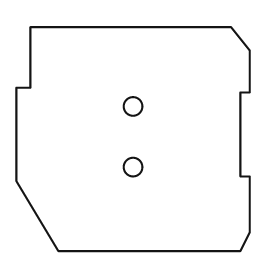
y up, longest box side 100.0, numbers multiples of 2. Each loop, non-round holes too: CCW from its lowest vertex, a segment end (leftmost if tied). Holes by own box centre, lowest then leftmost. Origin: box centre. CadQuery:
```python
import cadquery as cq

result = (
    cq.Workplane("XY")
    .moveTo(-32.0, -48.0)
    .lineTo(46.0, -48.0)
    .lineTo(50.0, -40.0)
    .lineTo(50.0, -16.0)
    .lineTo(46.0, -16.0)
    .lineTo(46.0, 20.0)
    .lineTo(50.0, 20.0)
    .lineTo(50.0, 38.0)
    .lineTo(42.0, 48.0)
    .lineTo(-44.0, 48.0)
    .lineTo(-44.0, 22.0)
    .lineTo(-50.0, 22.0)
    .lineTo(-50.0, -18.0)
    .close()
    .moveTo(0.0, -12.0)
    .circle(4.0)
    .moveTo(0.0, 14.0)
    .circle(4.0)
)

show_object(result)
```